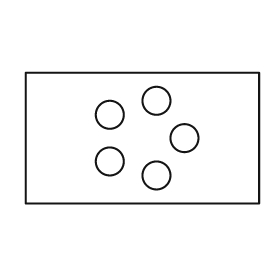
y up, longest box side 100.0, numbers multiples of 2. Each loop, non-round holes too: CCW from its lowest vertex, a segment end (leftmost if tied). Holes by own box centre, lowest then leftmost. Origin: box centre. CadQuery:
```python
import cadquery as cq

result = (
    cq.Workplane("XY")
    .moveTo(-50.0, -28.0)
    .lineTo(50.0, -28.0)
    .lineTo(50.0, 28.0)
    .lineTo(-50.0, 28.0)
    .close()
    .moveTo(6.0, -16.0)
    .circle(6.0)
    .moveTo(-14.0, -10.0)
    .circle(6.0)
    .moveTo(18.0, 0.0)
    .circle(6.0)
    .moveTo(-14.0, 10.0)
    .circle(6.0)
    .moveTo(6.0, 16.0)
    .circle(6.0)
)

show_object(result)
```